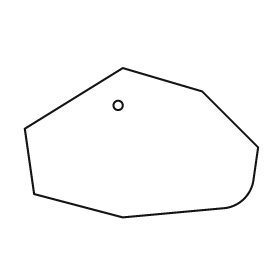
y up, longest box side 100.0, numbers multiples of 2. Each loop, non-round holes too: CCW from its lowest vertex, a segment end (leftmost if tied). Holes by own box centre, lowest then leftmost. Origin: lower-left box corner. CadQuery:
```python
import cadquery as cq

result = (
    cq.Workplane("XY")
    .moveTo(42.0, 0.0)
    .lineTo(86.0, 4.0)
    .threePointArc((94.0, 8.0), (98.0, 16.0))
    .lineTo(100.0, 30.0)
    .lineTo(76.0, 54.0)
    .lineTo(42.0, 64.0)
    .lineTo(0.0, 38.0)
    .lineTo(4.0, 10.0)
    .close()
    .moveTo(40.0, 48.0)
    .circle(2.0)
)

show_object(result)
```